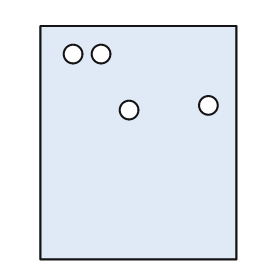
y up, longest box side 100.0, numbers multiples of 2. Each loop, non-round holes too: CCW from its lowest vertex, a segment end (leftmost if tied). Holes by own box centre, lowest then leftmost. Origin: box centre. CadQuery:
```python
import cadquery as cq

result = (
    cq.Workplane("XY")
    .moveTo(-42.0, -50.0)
    .lineTo(42.0, -50.0)
    .lineTo(42.0, 50.0)
    .lineTo(-42.0, 50.0)
    .close()
    .moveTo(-4.0, 14.0)
    .circle(4.0)
    .moveTo(30.0, 16.0)
    .circle(4.0)
    .moveTo(-28.0, 38.0)
    .circle(4.0)
    .moveTo(-16.0, 38.0)
    .circle(4.0)
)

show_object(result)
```